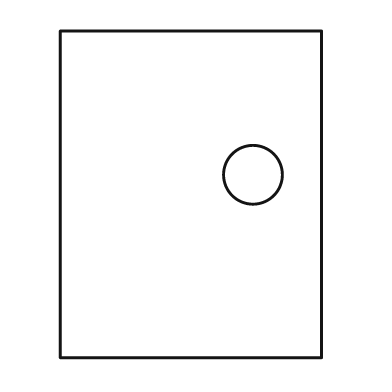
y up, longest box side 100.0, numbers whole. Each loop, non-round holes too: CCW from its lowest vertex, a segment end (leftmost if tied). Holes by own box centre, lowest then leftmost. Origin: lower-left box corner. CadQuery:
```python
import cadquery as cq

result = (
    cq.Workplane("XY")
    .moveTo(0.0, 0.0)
    .lineTo(80.0, 0.0)
    .lineTo(80.0, 100.0)
    .lineTo(0.0, 100.0)
    .close()
    .moveTo(59.0, 56.0)
    .circle(9.0)
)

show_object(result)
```